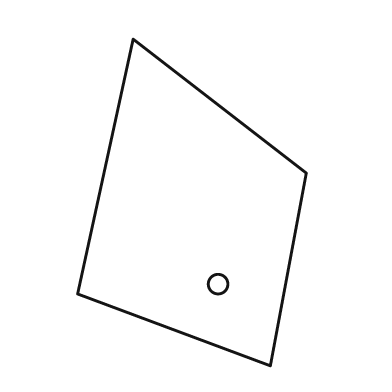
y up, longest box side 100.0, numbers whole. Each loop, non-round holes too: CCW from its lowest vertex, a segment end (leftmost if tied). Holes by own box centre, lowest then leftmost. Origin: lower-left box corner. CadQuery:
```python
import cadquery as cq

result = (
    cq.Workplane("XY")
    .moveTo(59.0, 0.0)
    .lineTo(70.0, 59.0)
    .lineTo(17.0, 100.0)
    .lineTo(0.0, 22.0)
    .close()
    .moveTo(43.0, 25.0)
    .circle(3.0)
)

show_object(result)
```